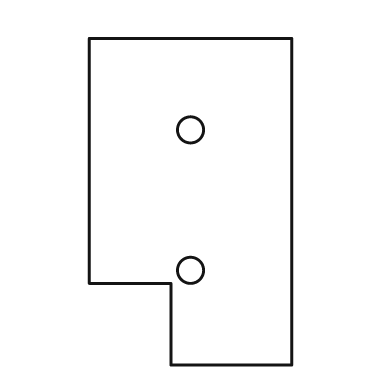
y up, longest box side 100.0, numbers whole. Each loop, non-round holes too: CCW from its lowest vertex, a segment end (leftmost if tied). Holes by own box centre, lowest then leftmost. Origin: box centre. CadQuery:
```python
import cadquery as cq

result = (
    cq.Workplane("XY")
    .moveTo(-6.0, -50.0)
    .lineTo(31.0, -50.0)
    .lineTo(31.0, 50.0)
    .lineTo(-31.0, 50.0)
    .lineTo(-31.0, -25.0)
    .lineTo(-6.0, -25.0)
    .close()
    .moveTo(0.0, -21.0)
    .circle(4.0)
    .moveTo(0.0, 22.0)
    .circle(4.0)
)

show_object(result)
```